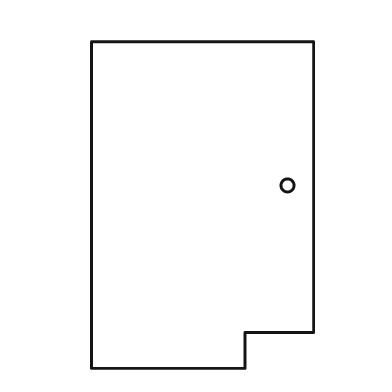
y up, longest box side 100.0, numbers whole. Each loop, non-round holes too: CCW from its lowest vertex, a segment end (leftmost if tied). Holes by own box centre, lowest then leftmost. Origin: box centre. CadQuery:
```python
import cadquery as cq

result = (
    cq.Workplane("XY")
    .moveTo(-34.0, -50.0)
    .lineTo(13.0, -50.0)
    .lineTo(13.0, -39.0)
    .lineTo(34.0, -39.0)
    .lineTo(34.0, 50.0)
    .lineTo(-34.0, 50.0)
    .close()
    .moveTo(26.0, 6.0)
    .circle(2.0)
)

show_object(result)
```